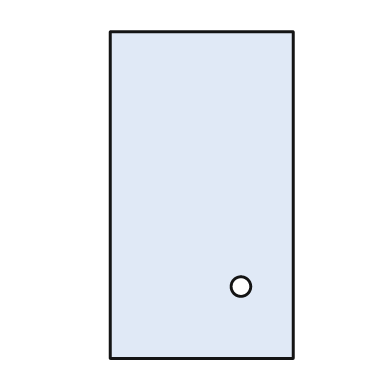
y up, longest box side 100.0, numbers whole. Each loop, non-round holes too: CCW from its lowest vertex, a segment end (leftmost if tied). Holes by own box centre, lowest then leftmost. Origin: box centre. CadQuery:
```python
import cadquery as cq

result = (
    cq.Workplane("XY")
    .moveTo(-28.0, -50.0)
    .lineTo(28.0, -50.0)
    .lineTo(28.0, 50.0)
    .lineTo(-28.0, 50.0)
    .close()
    .moveTo(12.0, -28.0)
    .circle(3.0)
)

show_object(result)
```